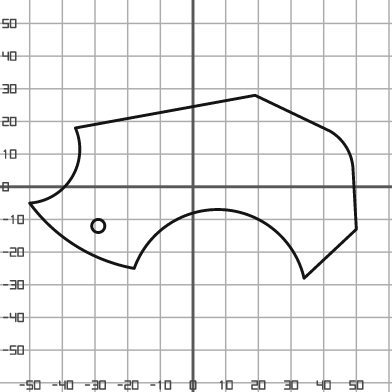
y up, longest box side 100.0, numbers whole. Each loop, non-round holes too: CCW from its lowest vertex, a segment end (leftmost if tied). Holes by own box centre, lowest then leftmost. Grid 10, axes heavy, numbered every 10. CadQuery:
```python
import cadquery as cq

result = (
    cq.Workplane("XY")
    .moveTo(34.0, -28.0)
    .lineTo(50.0, -13.0)
    .lineTo(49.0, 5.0)
    .threePointArc((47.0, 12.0), (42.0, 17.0))
    .lineTo(19.0, 28.0)
    .lineTo(-36.0, 18.0)
    .threePointArc((-37.0, 3.0), (-50.0, -5.0))
    .threePointArc((-36.0, -18.0), (-18.0, -25.0))
    .threePointArc((9.0, -7.0), (34.0, -28.0))
    .close()
    .moveTo(-29.0, -12.0)
    .circle(2.0)
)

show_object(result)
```